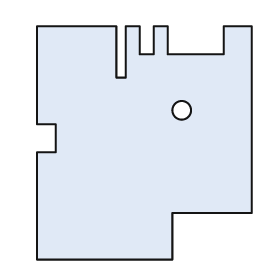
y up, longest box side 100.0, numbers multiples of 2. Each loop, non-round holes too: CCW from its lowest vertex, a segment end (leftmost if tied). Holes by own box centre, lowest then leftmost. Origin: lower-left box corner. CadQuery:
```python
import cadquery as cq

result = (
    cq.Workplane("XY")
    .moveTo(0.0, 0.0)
    .lineTo(58.0, 0.0)
    .lineTo(58.0, 20.0)
    .lineTo(92.0, 20.0)
    .lineTo(92.0, 100.0)
    .lineTo(80.0, 100.0)
    .lineTo(80.0, 88.0)
    .lineTo(56.0, 88.0)
    .lineTo(56.0, 100.0)
    .lineTo(50.0, 100.0)
    .lineTo(50.0, 88.0)
    .lineTo(44.0, 88.0)
    .lineTo(44.0, 100.0)
    .lineTo(38.0, 100.0)
    .lineTo(38.0, 78.0)
    .lineTo(34.0, 78.0)
    .lineTo(34.0, 100.0)
    .lineTo(0.0, 100.0)
    .lineTo(0.0, 58.0)
    .lineTo(8.0, 58.0)
    .lineTo(8.0, 46.0)
    .lineTo(0.0, 46.0)
    .close()
    .moveTo(62.0, 64.0)
    .circle(4.0)
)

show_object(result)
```